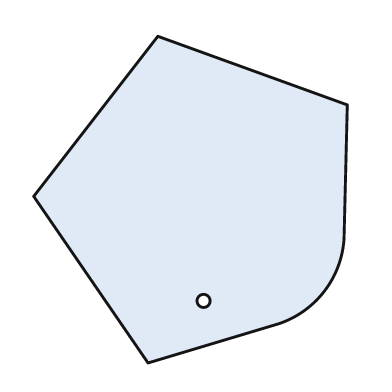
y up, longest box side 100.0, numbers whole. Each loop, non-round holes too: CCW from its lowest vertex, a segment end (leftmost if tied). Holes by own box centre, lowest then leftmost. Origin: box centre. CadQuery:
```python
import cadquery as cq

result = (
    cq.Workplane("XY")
    .moveTo(-13.0, -50.0)
    .lineTo(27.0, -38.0)
    .threePointArc((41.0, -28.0), (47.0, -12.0))
    .lineTo(48.0, 29.0)
    .lineTo(-10.0, 50.0)
    .lineTo(-48.0, 1.0)
    .close()
    .moveTo(4.0, -31.0)
    .circle(2.0)
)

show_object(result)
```